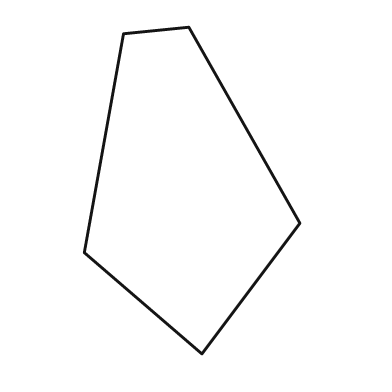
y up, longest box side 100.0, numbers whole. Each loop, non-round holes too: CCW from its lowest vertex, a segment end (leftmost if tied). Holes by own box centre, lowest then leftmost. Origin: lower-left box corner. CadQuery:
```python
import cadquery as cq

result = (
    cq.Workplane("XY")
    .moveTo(36.0, 0.0)
    .lineTo(66.0, 40.0)
    .lineTo(32.0, 100.0)
    .lineTo(12.0, 98.0)
    .lineTo(0.0, 31.0)
    .close()
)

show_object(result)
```